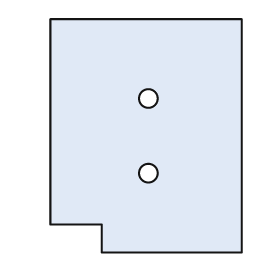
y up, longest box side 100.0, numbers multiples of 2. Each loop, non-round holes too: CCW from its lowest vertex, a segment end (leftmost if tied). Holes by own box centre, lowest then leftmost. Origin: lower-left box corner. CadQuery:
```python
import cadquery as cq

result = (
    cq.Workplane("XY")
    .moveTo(22.0, 0.0)
    .lineTo(82.0, 0.0)
    .lineTo(82.0, 100.0)
    .lineTo(0.0, 100.0)
    .lineTo(0.0, 12.0)
    .lineTo(22.0, 12.0)
    .close()
    .moveTo(42.0, 34.0)
    .circle(4.0)
    .moveTo(42.0, 66.0)
    .circle(4.0)
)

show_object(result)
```